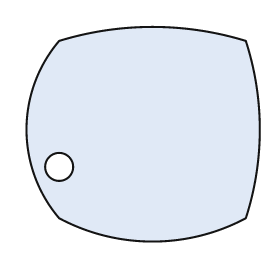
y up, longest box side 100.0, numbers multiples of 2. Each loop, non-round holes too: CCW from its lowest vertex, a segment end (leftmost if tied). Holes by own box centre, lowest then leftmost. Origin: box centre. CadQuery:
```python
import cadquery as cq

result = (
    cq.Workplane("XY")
    .moveTo(-36.0, -36.0)
    .threePointArc((4.0, -46.0), (44.0, -36.0))
    .threePointArc((50.0, 2.0), (44.0, 40.0))
    .threePointArc((4.0, 46.0), (-36.0, 40.0))
    .threePointArc((-50.0, 2.0), (-36.0, -36.0))
    .close()
    .moveTo(-36.0, -14.0)
    .circle(6.0)
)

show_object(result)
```